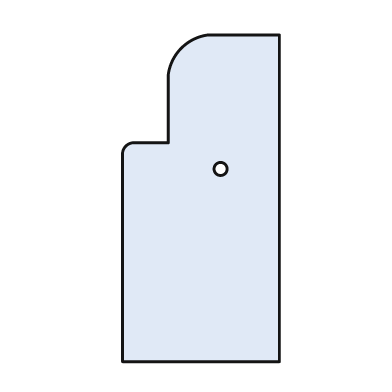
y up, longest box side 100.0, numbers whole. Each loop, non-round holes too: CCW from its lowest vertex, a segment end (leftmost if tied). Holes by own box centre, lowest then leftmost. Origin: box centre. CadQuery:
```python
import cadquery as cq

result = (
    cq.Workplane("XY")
    .moveTo(-24.0, -50.0)
    .lineTo(24.0, -50.0)
    .lineTo(24.0, 50.0)
    .lineTo(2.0, 50.0)
    .threePointArc((-6.0, 46.0), (-10.0, 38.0))
    .lineTo(-10.0, 17.0)
    .lineTo(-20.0, 17.0)
    .threePointArc((-23.0, 16.0), (-24.0, 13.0))
    .close()
    .moveTo(6.0, 9.0)
    .circle(2.0)
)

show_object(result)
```